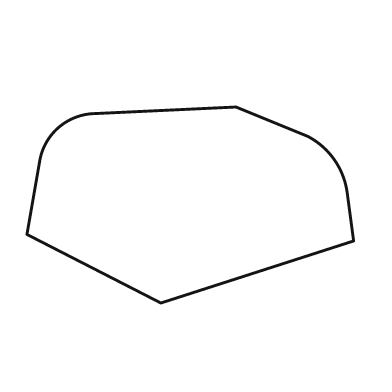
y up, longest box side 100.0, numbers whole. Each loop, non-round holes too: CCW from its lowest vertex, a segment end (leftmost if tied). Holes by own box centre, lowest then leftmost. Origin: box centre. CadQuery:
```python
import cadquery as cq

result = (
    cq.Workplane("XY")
    .moveTo(-9.0, -30.0)
    .lineTo(50.0, -11.0)
    .lineTo(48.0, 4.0)
    .threePointArc((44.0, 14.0), (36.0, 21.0))
    .lineTo(14.0, 30.0)
    .lineTo(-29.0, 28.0)
    .threePointArc((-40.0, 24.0), (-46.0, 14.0))
    .lineTo(-50.0, -9.0)
    .close()
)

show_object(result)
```